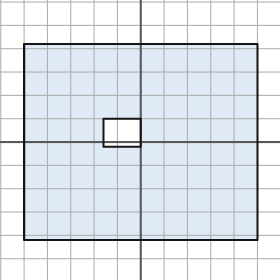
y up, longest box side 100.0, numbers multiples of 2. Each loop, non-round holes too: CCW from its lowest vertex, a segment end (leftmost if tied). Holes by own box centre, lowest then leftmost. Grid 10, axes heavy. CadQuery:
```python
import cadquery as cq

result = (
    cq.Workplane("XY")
    .moveTo(-50.0, -42.0)
    .lineTo(50.0, -42.0)
    .lineTo(50.0, 42.0)
    .lineTo(-50.0, 42.0)
    .close()
    .moveTo(-16.0, -2.0)
    .lineTo(0.0, -2.0)
    .lineTo(0.0, 10.0)
    .lineTo(-16.0, 10.0)
    .close()
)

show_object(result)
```